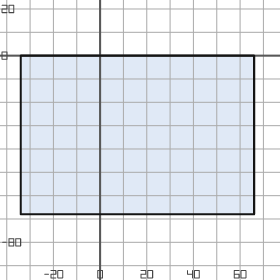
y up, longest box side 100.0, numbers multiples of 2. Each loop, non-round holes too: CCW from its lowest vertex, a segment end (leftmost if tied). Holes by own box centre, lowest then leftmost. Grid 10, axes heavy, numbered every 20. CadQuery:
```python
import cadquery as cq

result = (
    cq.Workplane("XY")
    .moveTo(-34.0, -68.0)
    .lineTo(66.0, -68.0)
    .lineTo(66.0, 0.0)
    .lineTo(-34.0, 0.0)
    .close()
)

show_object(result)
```